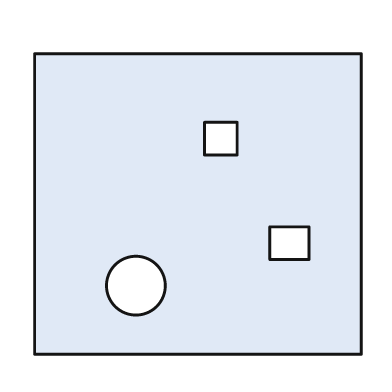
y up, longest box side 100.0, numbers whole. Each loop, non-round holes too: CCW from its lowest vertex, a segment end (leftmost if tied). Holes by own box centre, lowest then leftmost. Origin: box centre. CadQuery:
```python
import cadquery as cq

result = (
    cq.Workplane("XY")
    .moveTo(-50.0, -46.0)
    .lineTo(50.0, -46.0)
    .lineTo(50.0, 46.0)
    .lineTo(-50.0, 46.0)
    .close()
    .moveTo(-19.0, -25.0)
    .circle(9.0)
    .moveTo(22.0, -17.0)
    .lineTo(34.0, -17.0)
    .lineTo(34.0, -7.0)
    .lineTo(22.0, -7.0)
    .close()
    .moveTo(2.0, 15.0)
    .lineTo(12.0, 15.0)
    .lineTo(12.0, 25.0)
    .lineTo(2.0, 25.0)
    .close()
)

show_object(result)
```